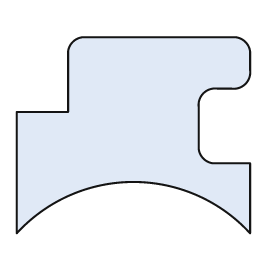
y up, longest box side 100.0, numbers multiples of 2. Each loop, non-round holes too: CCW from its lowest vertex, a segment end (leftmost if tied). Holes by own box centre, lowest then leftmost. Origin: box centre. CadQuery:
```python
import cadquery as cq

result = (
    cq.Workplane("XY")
    .moveTo(-50.0, -42.0)
    .threePointArc((0.0, -20.0), (50.0, -42.0))
    .lineTo(50.0, -12.0)
    .lineTo(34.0, -12.0)
    .threePointArc((30.0, -10.0), (28.0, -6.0))
    .lineTo(28.0, 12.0)
    .threePointArc((30.0, 18.0), (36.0, 20.0))
    .lineTo(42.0, 20.0)
    .threePointArc((48.0, 22.0), (50.0, 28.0))
    .lineTo(50.0, 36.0)
    .threePointArc((48.0, 40.0), (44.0, 42.0))
    .lineTo(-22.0, 42.0)
    .threePointArc((-26.0, 40.0), (-28.0, 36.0))
    .lineTo(-28.0, 10.0)
    .lineTo(-50.0, 10.0)
    .close()
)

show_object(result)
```